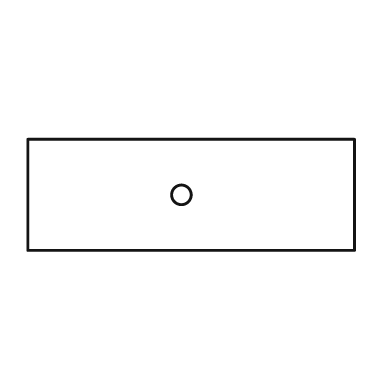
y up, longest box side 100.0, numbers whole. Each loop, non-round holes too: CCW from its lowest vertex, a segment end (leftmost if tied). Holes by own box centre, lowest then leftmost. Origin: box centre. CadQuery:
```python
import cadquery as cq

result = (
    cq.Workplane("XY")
    .moveTo(-50.0, -17.0)
    .lineTo(50.0, -17.0)
    .lineTo(50.0, 17.0)
    .lineTo(-50.0, 17.0)
    .close()
    .moveTo(-3.0, 0.0)
    .circle(3.0)
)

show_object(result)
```